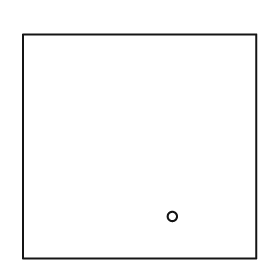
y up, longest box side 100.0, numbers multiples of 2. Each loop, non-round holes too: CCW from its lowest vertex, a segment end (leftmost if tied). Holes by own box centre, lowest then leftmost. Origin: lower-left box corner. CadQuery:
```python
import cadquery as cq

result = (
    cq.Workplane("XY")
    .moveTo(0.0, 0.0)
    .lineTo(100.0, 0.0)
    .lineTo(100.0, 96.0)
    .lineTo(0.0, 96.0)
    .close()
    .moveTo(64.0, 18.0)
    .circle(2.0)
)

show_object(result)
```